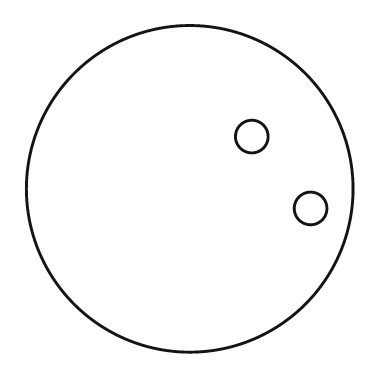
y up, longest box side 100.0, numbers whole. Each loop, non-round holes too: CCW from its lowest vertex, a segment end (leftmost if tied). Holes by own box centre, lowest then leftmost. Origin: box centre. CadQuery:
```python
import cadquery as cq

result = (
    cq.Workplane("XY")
    .moveTo(0.0, 0.0)
    .circle(50.0)
    .moveTo(37.0, -6.0)
    .circle(5.0)
    .moveTo(19.0, 16.0)
    .circle(5.0)
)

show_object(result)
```